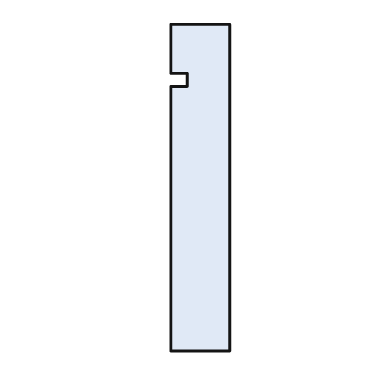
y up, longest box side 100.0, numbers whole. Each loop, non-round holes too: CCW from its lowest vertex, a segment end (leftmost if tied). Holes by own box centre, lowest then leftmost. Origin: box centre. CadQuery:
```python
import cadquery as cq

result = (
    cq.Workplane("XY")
    .moveTo(-9.0, -50.0)
    .lineTo(9.0, -50.0)
    .lineTo(9.0, 50.0)
    .lineTo(-9.0, 50.0)
    .lineTo(-9.0, 35.0)
    .lineTo(-4.0, 35.0)
    .lineTo(-4.0, 31.0)
    .lineTo(-9.0, 31.0)
    .close()
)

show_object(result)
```